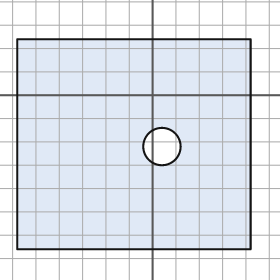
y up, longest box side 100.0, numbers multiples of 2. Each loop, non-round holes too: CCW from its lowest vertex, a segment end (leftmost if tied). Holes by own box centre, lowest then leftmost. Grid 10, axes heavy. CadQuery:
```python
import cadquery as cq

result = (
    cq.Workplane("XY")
    .moveTo(-58.0, -66.0)
    .lineTo(42.0, -66.0)
    .lineTo(42.0, 24.0)
    .lineTo(-58.0, 24.0)
    .close()
    .moveTo(4.0, -22.0)
    .circle(8.0)
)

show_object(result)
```